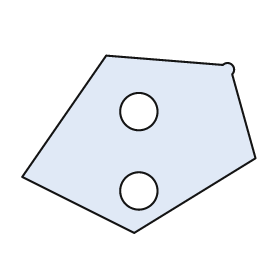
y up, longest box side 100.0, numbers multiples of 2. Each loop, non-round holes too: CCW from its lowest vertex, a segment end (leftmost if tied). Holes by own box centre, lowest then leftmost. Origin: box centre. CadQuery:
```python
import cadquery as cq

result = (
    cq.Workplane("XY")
    .moveTo(-2.0, -38.0)
    .lineTo(50.0, -6.0)
    .lineTo(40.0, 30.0)
    .threePointArc((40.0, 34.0), (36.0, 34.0))
    .lineTo(-14.0, 38.0)
    .lineTo(-50.0, -14.0)
    .close()
    .moveTo(0.0, -20.0)
    .circle(8.0)
    .moveTo(0.0, 14.0)
    .circle(8.0)
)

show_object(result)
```